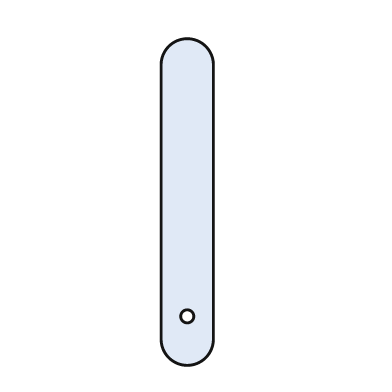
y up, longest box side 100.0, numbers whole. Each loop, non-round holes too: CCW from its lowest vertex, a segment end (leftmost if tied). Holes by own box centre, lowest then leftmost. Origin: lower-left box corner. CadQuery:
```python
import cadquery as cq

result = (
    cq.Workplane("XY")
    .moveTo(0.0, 8.0)
    .threePointArc((8.0, 0.0), (16.0, 8.0))
    .lineTo(16.0, 92.0)
    .threePointArc((8.0, 100.0), (0.0, 92.0))
    .close()
    .moveTo(8.0, 15.0)
    .circle(2.0)
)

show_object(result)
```